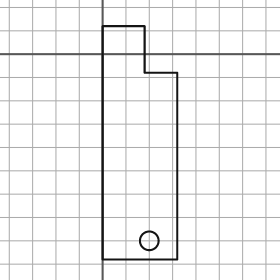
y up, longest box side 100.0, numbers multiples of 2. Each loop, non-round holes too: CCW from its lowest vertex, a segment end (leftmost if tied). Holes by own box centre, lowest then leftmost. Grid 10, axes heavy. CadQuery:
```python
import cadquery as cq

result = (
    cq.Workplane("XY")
    .moveTo(0.0, -88.0)
    .lineTo(32.0, -88.0)
    .lineTo(32.0, -8.0)
    .lineTo(18.0, -8.0)
    .lineTo(18.0, 12.0)
    .lineTo(0.0, 12.0)
    .close()
    .moveTo(20.0, -80.0)
    .circle(4.0)
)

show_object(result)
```